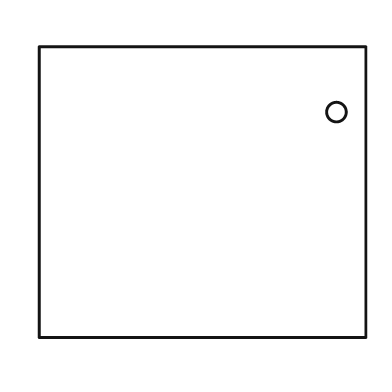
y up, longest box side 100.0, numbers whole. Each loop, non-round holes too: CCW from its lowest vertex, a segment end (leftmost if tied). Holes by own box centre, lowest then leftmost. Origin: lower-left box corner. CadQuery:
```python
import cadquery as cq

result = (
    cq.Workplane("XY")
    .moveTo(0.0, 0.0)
    .lineTo(100.0, 0.0)
    .lineTo(100.0, 89.0)
    .lineTo(0.0, 89.0)
    .close()
    .moveTo(91.0, 69.0)
    .circle(3.0)
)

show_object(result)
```